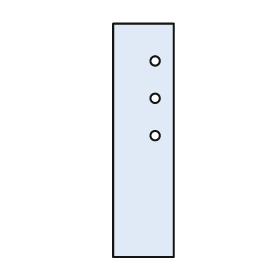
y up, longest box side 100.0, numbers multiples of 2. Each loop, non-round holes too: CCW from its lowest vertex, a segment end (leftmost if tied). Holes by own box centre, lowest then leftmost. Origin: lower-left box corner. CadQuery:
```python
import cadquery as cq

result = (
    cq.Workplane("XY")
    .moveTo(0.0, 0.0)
    .lineTo(26.0, 0.0)
    .lineTo(26.0, 100.0)
    .lineTo(0.0, 100.0)
    .close()
    .moveTo(18.0, 52.0)
    .circle(2.0)
    .moveTo(18.0, 68.0)
    .circle(2.0)
    .moveTo(18.0, 84.0)
    .circle(2.0)
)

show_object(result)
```